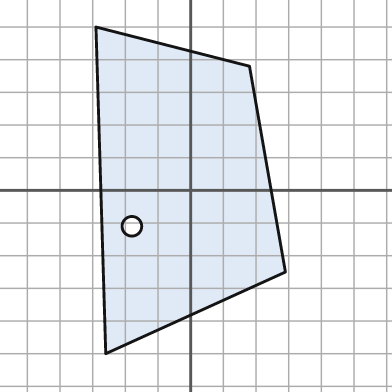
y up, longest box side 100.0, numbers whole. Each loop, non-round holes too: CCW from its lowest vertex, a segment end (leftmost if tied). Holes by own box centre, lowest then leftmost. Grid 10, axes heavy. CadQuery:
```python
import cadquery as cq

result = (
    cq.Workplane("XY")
    .moveTo(-26.0, -50.0)
    .lineTo(29.0, -25.0)
    .lineTo(18.0, 38.0)
    .lineTo(-29.0, 50.0)
    .close()
    .moveTo(-18.0, -11.0)
    .circle(3.0)
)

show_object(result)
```